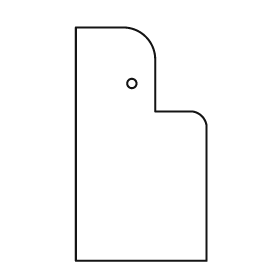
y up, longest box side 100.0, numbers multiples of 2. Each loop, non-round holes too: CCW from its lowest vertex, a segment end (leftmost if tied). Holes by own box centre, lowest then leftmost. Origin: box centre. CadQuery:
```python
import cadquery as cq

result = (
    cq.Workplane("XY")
    .moveTo(-28.0, -50.0)
    .lineTo(28.0, -50.0)
    .lineTo(28.0, 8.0)
    .threePointArc((26.0, 12.0), (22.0, 14.0))
    .lineTo(6.0, 14.0)
    .lineTo(6.0, 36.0)
    .threePointArc((2.0, 46.0), (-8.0, 50.0))
    .lineTo(-28.0, 50.0)
    .close()
    .moveTo(-4.0, 26.0)
    .circle(2.0)
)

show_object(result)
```